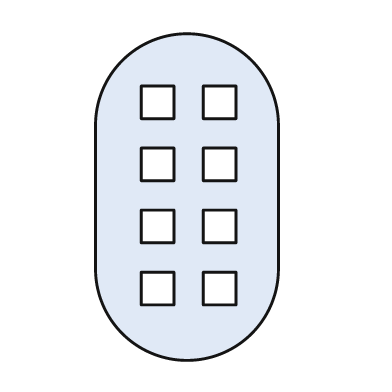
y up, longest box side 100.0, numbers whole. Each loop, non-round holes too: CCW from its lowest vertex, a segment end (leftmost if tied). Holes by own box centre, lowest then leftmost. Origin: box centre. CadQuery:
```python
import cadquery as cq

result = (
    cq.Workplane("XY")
    .moveTo(-28.0, -22.0)
    .threePointArc((0.0, -50.0), (28.0, -22.0))
    .lineTo(28.0, 22.0)
    .threePointArc((0.0, 50.0), (-28.0, 22.0))
    .close()
    .moveTo(-14.0, -33.0)
    .lineTo(-4.0, -33.0)
    .lineTo(-4.0, -23.0)
    .lineTo(-14.0, -23.0)
    .close()
    .moveTo(5.0, -33.0)
    .lineTo(15.0, -33.0)
    .lineTo(15.0, -23.0)
    .lineTo(5.0, -23.0)
    .close()
    .moveTo(-14.0, -14.0)
    .lineTo(-4.0, -14.0)
    .lineTo(-4.0, -4.0)
    .lineTo(-14.0, -4.0)
    .close()
    .moveTo(5.0, -14.0)
    .lineTo(15.0, -14.0)
    .lineTo(15.0, -4.0)
    .lineTo(5.0, -4.0)
    .close()
    .moveTo(-14.0, 5.0)
    .lineTo(-4.0, 5.0)
    .lineTo(-4.0, 15.0)
    .lineTo(-14.0, 15.0)
    .close()
    .moveTo(5.0, 5.0)
    .lineTo(15.0, 5.0)
    .lineTo(15.0, 15.0)
    .lineTo(5.0, 15.0)
    .close()
    .moveTo(-14.0, 24.0)
    .lineTo(-4.0, 24.0)
    .lineTo(-4.0, 34.0)
    .lineTo(-14.0, 34.0)
    .close()
    .moveTo(5.0, 24.0)
    .lineTo(15.0, 24.0)
    .lineTo(15.0, 34.0)
    .lineTo(5.0, 34.0)
    .close()
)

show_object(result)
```